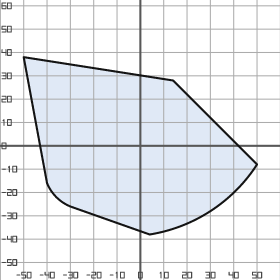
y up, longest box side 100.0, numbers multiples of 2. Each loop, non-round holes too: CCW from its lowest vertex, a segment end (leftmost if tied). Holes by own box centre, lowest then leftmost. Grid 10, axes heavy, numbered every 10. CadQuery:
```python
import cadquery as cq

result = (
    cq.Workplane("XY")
    .moveTo(4.0, -38.0)
    .threePointArc((30.0, -28.0), (50.0, -8.0))
    .lineTo(14.0, 28.0)
    .lineTo(-50.0, 38.0)
    .lineTo(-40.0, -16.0)
    .threePointArc((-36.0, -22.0), (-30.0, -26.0))
    .close()
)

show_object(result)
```